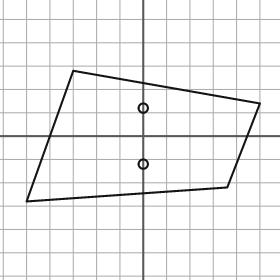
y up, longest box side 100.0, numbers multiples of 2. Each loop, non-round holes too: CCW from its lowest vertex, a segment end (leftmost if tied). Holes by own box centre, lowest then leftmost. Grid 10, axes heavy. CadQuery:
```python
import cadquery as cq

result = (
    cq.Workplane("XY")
    .moveTo(-50.0, -28.0)
    .lineTo(36.0, -22.0)
    .lineTo(50.0, 14.0)
    .lineTo(-30.0, 28.0)
    .close()
    .moveTo(0.0, -12.0)
    .circle(2.0)
    .moveTo(0.0, 12.0)
    .circle(2.0)
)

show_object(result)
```